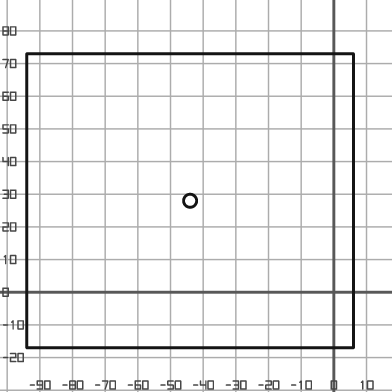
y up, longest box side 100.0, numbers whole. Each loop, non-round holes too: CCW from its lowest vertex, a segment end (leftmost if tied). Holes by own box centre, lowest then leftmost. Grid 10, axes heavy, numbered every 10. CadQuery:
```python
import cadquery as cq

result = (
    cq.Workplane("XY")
    .moveTo(-94.0, -17.0)
    .lineTo(6.0, -17.0)
    .lineTo(6.0, 73.0)
    .lineTo(-94.0, 73.0)
    .close()
    .moveTo(-44.0, 28.0)
    .circle(2.0)
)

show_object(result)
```